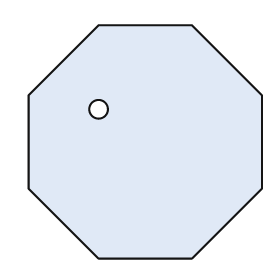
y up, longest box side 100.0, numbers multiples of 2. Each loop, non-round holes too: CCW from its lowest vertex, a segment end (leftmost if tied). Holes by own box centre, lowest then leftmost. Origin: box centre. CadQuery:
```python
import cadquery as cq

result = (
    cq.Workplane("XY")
    .moveTo(-20.0, -50.0)
    .lineTo(20.0, -50.0)
    .lineTo(50.0, -20.0)
    .lineTo(50.0, 20.0)
    .lineTo(20.0, 50.0)
    .lineTo(-20.0, 50.0)
    .lineTo(-50.0, 20.0)
    .lineTo(-50.0, -20.0)
    .close()
    .moveTo(-20.0, 14.0)
    .circle(4.0)
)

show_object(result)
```